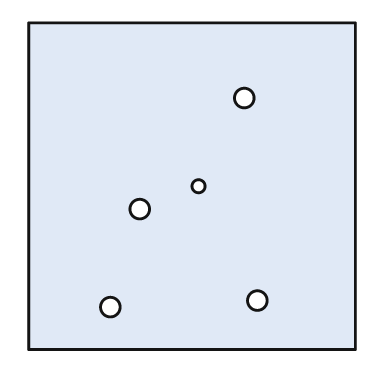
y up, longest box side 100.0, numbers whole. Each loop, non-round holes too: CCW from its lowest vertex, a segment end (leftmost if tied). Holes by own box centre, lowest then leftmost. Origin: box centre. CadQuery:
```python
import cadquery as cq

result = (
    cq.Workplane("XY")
    .moveTo(-50.0, -50.0)
    .lineTo(50.0, -50.0)
    .lineTo(50.0, 50.0)
    .lineTo(-50.0, 50.0)
    .close()
    .moveTo(-25.0, -37.0)
    .circle(3.0)
    .moveTo(20.0, -35.0)
    .circle(3.0)
    .moveTo(-16.0, -7.0)
    .circle(3.0)
    .moveTo(2.0, 0.0)
    .circle(2.0)
    .moveTo(16.0, 27.0)
    .circle(3.0)
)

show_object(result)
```